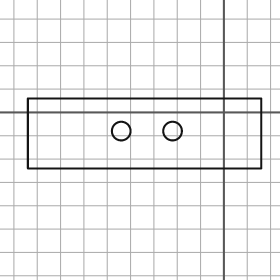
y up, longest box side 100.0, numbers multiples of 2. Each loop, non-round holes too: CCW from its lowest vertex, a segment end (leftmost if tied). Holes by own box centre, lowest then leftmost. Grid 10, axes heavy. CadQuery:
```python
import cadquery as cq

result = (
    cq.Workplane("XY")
    .moveTo(-84.0, -24.0)
    .lineTo(16.0, -24.0)
    .lineTo(16.0, 6.0)
    .lineTo(-84.0, 6.0)
    .close()
    .moveTo(-44.0, -8.0)
    .circle(4.0)
    .moveTo(-22.0, -8.0)
    .circle(4.0)
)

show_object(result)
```